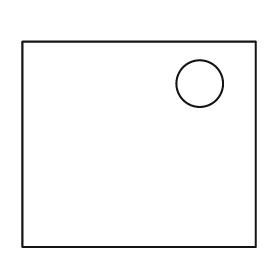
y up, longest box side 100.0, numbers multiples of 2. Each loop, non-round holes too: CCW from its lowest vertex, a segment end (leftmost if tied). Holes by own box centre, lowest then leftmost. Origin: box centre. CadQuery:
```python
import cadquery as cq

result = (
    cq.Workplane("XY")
    .moveTo(-50.0, -44.0)
    .lineTo(50.0, -44.0)
    .lineTo(50.0, 44.0)
    .lineTo(-50.0, 44.0)
    .close()
    .moveTo(26.0, 26.0)
    .circle(10.0)
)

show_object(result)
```